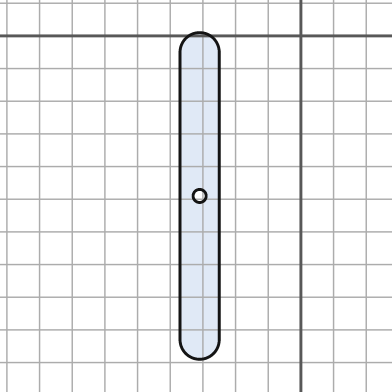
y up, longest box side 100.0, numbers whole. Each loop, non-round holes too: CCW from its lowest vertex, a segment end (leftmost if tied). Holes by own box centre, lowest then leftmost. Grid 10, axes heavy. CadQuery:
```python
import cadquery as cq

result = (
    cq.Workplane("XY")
    .moveTo(-37.0, -93.0)
    .threePointArc((-31.0, -99.0), (-25.0, -93.0))
    .lineTo(-25.0, -5.0)
    .threePointArc((-31.0, 1.0), (-37.0, -5.0))
    .close()
    .moveTo(-31.0, -49.0)
    .circle(2.0)
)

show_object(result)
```